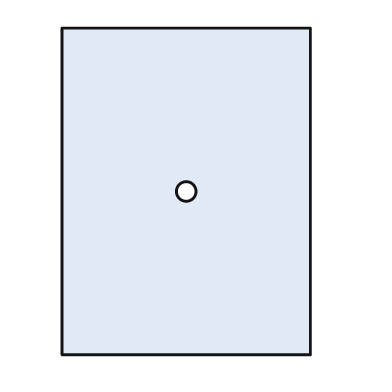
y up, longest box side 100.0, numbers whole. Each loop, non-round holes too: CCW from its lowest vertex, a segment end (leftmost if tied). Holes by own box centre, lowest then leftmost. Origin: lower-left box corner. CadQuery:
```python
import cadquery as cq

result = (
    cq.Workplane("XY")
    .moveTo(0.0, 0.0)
    .lineTo(76.0, 0.0)
    .lineTo(76.0, 100.0)
    .lineTo(0.0, 100.0)
    .close()
    .moveTo(38.0, 50.0)
    .circle(3.0)
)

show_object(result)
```